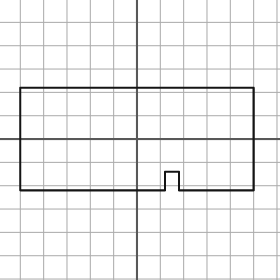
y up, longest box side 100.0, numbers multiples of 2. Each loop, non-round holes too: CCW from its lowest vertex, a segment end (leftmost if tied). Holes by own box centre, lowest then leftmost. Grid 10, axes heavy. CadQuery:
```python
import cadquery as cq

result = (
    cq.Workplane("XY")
    .moveTo(-50.0, -22.0)
    .lineTo(12.0, -22.0)
    .lineTo(12.0, -14.0)
    .lineTo(18.0, -14.0)
    .lineTo(18.0, -22.0)
    .lineTo(50.0, -22.0)
    .lineTo(50.0, 22.0)
    .lineTo(-50.0, 22.0)
    .close()
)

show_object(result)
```